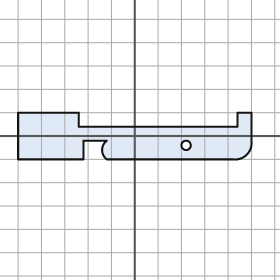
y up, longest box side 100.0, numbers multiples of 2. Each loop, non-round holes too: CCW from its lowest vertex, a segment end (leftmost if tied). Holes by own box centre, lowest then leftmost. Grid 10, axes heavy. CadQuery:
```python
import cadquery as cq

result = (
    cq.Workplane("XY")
    .moveTo(-50.0, -10.0)
    .lineTo(-22.0, -10.0)
    .lineTo(-22.0, -2.0)
    .lineTo(-12.0, -2.0)
    .threePointArc((-14.0, -6.0), (-12.0, -10.0))
    .lineTo(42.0, -10.0)
    .threePointArc((48.0, -8.0), (50.0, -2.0))
    .lineTo(50.0, 10.0)
    .lineTo(44.0, 10.0)
    .lineTo(44.0, 4.0)
    .lineTo(-24.0, 4.0)
    .lineTo(-24.0, 10.0)
    .lineTo(-50.0, 10.0)
    .close()
    .moveTo(22.0, -4.0)
    .circle(2.0)
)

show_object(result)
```